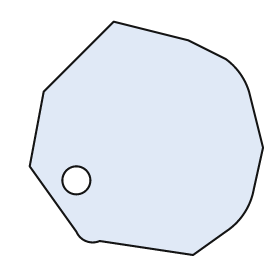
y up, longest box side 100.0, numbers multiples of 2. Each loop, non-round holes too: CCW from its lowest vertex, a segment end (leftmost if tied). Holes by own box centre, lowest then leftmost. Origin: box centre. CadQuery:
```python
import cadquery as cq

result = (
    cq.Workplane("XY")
    .moveTo(20.0, -50.0)
    .lineTo(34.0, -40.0)
    .threePointArc((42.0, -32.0), (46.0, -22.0))
    .lineTo(50.0, -4.0)
    .lineTo(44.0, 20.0)
    .threePointArc((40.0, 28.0), (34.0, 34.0))
    .lineTo(18.0, 42.0)
    .lineTo(-14.0, 50.0)
    .lineTo(-44.0, 20.0)
    .lineTo(-50.0, -12.0)
    .lineTo(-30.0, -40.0)
    .threePointArc((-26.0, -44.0), (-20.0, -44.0))
    .close()
    .moveTo(-30.0, -18.0)
    .circle(6.0)
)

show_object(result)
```